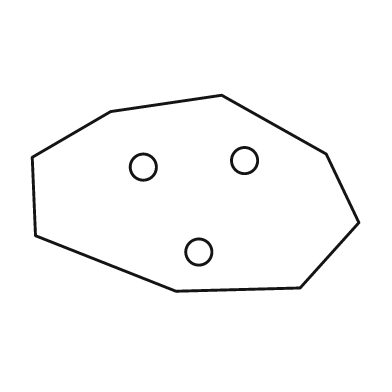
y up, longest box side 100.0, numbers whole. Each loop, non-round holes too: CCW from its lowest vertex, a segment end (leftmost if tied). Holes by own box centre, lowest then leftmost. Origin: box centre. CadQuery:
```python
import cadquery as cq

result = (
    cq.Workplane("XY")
    .moveTo(-6.0, -30.0)
    .lineTo(32.0, -29.0)
    .lineTo(50.0, -9.0)
    .lineTo(40.0, 12.0)
    .lineTo(8.0, 30.0)
    .lineTo(-26.0, 25.0)
    .lineTo(-50.0, 11.0)
    .lineTo(-49.0, -13.0)
    .close()
    .moveTo(1.0, -18.0)
    .circle(4.0)
    .moveTo(-16.0, 8.0)
    .circle(4.0)
    .moveTo(15.0, 10.0)
    .circle(4.0)
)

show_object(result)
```